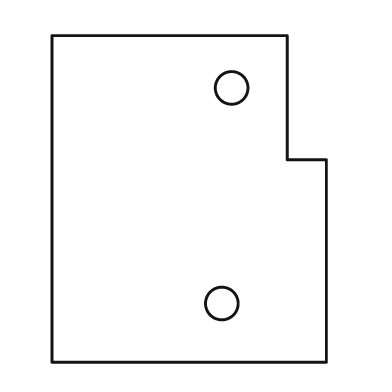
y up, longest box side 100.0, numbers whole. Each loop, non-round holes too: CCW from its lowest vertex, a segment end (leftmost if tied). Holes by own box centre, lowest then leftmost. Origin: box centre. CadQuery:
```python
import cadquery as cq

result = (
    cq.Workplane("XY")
    .moveTo(-42.0, -50.0)
    .lineTo(42.0, -50.0)
    .lineTo(42.0, 12.0)
    .lineTo(30.0, 12.0)
    .lineTo(30.0, 50.0)
    .lineTo(-42.0, 50.0)
    .close()
    .moveTo(10.0, -32.0)
    .circle(5.0)
    .moveTo(13.0, 34.0)
    .circle(5.0)
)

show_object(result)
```